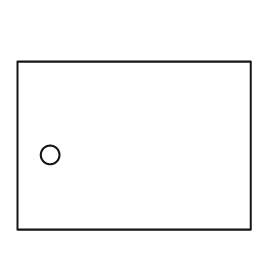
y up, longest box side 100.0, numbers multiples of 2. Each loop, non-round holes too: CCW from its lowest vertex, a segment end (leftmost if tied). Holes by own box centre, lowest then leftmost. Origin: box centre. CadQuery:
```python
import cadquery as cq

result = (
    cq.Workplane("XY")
    .moveTo(-50.0, -36.0)
    .lineTo(50.0, -36.0)
    .lineTo(50.0, 36.0)
    .lineTo(-50.0, 36.0)
    .close()
    .moveTo(-36.0, -4.0)
    .circle(4.0)
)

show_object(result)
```